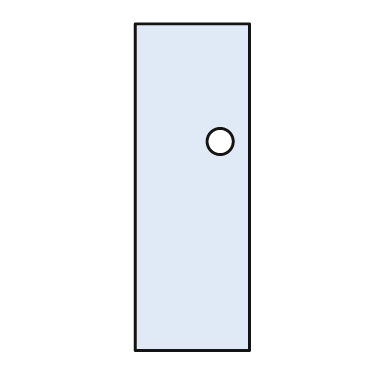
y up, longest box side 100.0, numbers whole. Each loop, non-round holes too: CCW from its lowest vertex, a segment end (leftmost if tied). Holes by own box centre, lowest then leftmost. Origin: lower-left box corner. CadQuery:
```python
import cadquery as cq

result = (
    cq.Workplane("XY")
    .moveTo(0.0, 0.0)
    .lineTo(35.0, 0.0)
    .lineTo(35.0, 100.0)
    .lineTo(0.0, 100.0)
    .close()
    .moveTo(26.0, 64.0)
    .circle(4.0)
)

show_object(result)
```